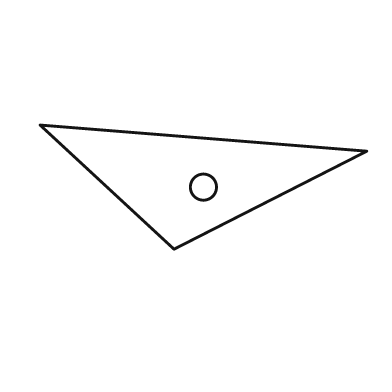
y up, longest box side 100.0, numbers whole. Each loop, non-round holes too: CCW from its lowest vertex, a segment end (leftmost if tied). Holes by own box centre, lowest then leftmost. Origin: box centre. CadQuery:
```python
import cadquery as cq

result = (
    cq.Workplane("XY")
    .moveTo(-9.0, -19.0)
    .lineTo(50.0, 11.0)
    .lineTo(-50.0, 19.0)
    .close()
    .moveTo(0.0, 0.0)
    .circle(4.0)
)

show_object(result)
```